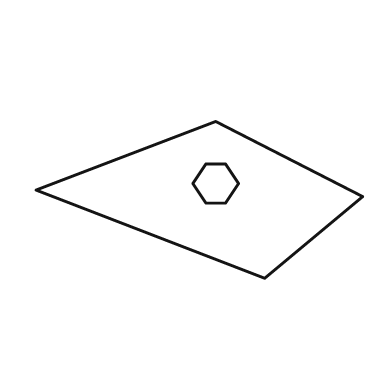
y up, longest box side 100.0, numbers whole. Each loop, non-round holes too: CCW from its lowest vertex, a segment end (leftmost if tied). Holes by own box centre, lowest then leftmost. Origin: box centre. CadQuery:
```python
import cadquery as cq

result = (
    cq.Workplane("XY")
    .moveTo(20.0, -24.0)
    .lineTo(50.0, 1.0)
    .lineTo(5.0, 24.0)
    .lineTo(-50.0, 3.0)
    .close()
    .moveTo(2.0, -1.0)
    .lineTo(8.0, -1.0)
    .lineTo(12.0, 5.0)
    .lineTo(8.0, 11.0)
    .lineTo(2.0, 11.0)
    .lineTo(-2.0, 5.0)
    .close()
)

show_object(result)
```